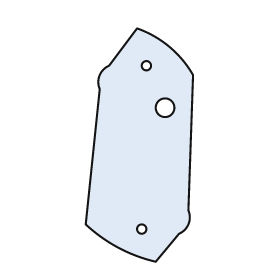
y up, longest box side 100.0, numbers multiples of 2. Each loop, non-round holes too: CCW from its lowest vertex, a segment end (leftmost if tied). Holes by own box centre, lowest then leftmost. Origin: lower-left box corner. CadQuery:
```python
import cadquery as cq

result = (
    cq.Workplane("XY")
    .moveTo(30.0, 0.0)
    .lineTo(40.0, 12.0)
    .threePointArc((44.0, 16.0), (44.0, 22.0))
    .lineTo(46.0, 80.0)
    .threePointArc((36.0, 92.0), (22.0, 100.0))
    .lineTo(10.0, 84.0)
    .threePointArc((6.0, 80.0), (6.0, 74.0))
    .lineTo(0.0, 16.0)
    .threePointArc((14.0, 6.0), (30.0, 0.0))
    .close()
    .moveTo(24.0, 14.0)
    .circle(2.0)
    .moveTo(34.0, 66.0)
    .circle(4.0)
    .moveTo(26.0, 84.0)
    .circle(2.0)
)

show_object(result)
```